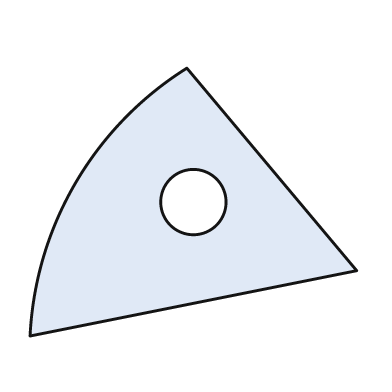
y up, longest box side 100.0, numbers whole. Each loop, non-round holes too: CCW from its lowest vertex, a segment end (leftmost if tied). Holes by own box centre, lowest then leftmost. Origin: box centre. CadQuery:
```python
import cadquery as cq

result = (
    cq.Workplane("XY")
    .moveTo(-50.0, -41.0)
    .lineTo(50.0, -21.0)
    .lineTo(-2.0, 41.0)
    .threePointArc((-36.0, 6.0), (-50.0, -41.0))
    .close()
    .moveTo(0.0, 0.0)
    .circle(10.0)
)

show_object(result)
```